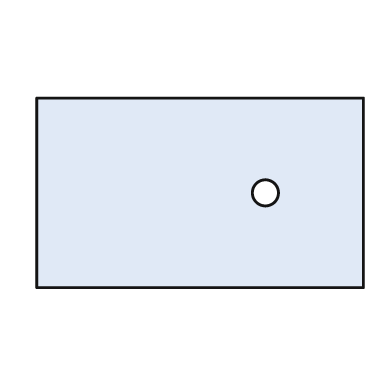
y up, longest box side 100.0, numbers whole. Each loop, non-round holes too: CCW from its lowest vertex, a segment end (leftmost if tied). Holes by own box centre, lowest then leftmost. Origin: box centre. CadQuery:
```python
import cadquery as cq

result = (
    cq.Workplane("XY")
    .moveTo(-50.0, -29.0)
    .lineTo(50.0, -29.0)
    .lineTo(50.0, 29.0)
    .lineTo(-50.0, 29.0)
    .close()
    .moveTo(20.0, 0.0)
    .circle(4.0)
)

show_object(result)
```